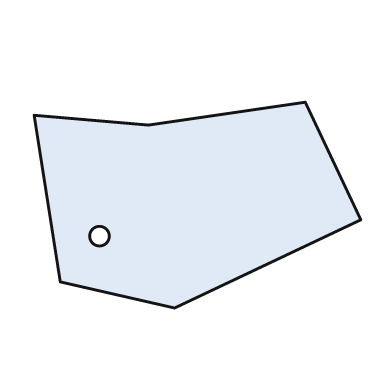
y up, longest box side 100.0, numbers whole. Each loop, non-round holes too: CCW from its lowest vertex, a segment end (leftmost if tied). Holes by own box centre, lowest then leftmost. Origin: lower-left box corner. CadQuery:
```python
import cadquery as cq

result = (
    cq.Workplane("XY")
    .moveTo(43.0, 0.0)
    .lineTo(100.0, 27.0)
    .lineTo(83.0, 63.0)
    .lineTo(35.0, 56.0)
    .lineTo(0.0, 59.0)
    .lineTo(8.0, 8.0)
    .close()
    .moveTo(20.0, 22.0)
    .circle(3.0)
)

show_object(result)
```